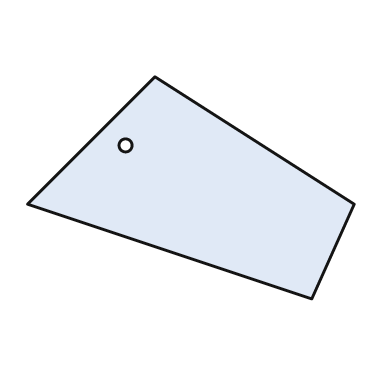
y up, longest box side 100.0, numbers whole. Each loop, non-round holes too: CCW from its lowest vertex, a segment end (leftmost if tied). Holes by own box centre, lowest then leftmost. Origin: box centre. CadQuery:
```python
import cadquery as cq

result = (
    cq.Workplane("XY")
    .moveTo(37.0, -34.0)
    .lineTo(50.0, -5.0)
    .lineTo(-11.0, 34.0)
    .lineTo(-50.0, -5.0)
    .close()
    .moveTo(-20.0, 13.0)
    .circle(2.0)
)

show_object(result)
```